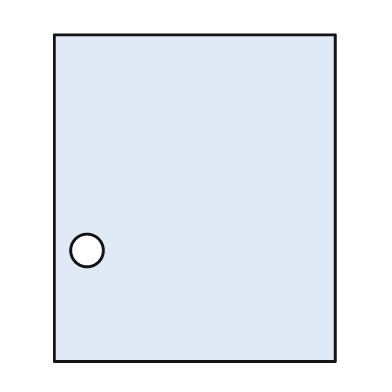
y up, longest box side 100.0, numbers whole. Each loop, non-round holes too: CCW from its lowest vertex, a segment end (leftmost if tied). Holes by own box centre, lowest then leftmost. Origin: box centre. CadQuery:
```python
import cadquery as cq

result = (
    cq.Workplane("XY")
    .moveTo(-43.0, -50.0)
    .lineTo(43.0, -50.0)
    .lineTo(43.0, 50.0)
    .lineTo(-43.0, 50.0)
    .close()
    .moveTo(-33.0, -16.0)
    .circle(5.0)
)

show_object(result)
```